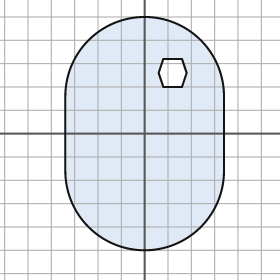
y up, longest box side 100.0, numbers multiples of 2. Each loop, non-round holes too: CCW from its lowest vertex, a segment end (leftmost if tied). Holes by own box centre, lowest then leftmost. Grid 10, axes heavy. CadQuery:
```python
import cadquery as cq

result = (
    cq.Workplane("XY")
    .moveTo(-34.0, -16.0)
    .threePointArc((0.0, -50.0), (34.0, -16.0))
    .lineTo(34.0, 16.0)
    .threePointArc((0.0, 50.0), (-34.0, 16.0))
    .close()
    .moveTo(8.0, 20.0)
    .lineTo(16.0, 20.0)
    .lineTo(18.0, 26.0)
    .lineTo(16.0, 32.0)
    .lineTo(8.0, 32.0)
    .lineTo(6.0, 26.0)
    .close()
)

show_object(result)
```